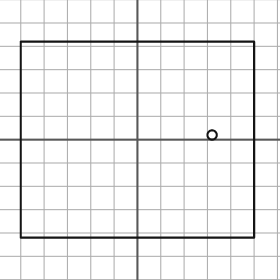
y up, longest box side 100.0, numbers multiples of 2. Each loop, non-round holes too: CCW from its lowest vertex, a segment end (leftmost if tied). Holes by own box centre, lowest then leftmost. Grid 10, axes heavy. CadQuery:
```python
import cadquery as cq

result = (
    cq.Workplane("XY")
    .moveTo(-50.0, -42.0)
    .lineTo(50.0, -42.0)
    .lineTo(50.0, 42.0)
    .lineTo(-50.0, 42.0)
    .close()
    .moveTo(32.0, 2.0)
    .circle(2.0)
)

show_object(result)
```